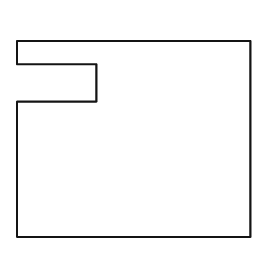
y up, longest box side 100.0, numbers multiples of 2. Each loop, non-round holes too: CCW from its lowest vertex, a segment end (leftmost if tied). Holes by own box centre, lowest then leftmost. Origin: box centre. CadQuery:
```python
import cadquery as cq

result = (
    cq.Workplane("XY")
    .moveTo(-50.0, -42.0)
    .lineTo(50.0, -42.0)
    .lineTo(50.0, 42.0)
    .lineTo(-50.0, 42.0)
    .lineTo(-50.0, 32.0)
    .lineTo(-16.0, 32.0)
    .lineTo(-16.0, 16.0)
    .lineTo(-50.0, 16.0)
    .close()
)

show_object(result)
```